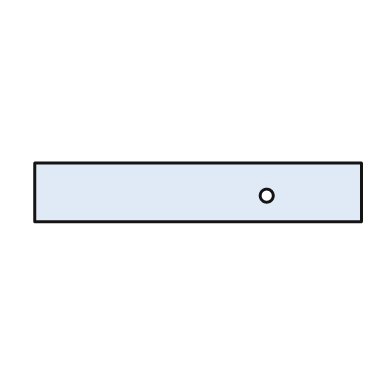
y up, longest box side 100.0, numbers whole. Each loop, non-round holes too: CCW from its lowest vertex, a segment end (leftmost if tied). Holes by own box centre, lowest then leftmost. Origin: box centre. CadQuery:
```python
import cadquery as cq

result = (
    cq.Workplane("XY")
    .moveTo(-50.0, -9.0)
    .lineTo(50.0, -9.0)
    .lineTo(50.0, 9.0)
    .lineTo(-50.0, 9.0)
    .close()
    .moveTo(21.0, -1.0)
    .circle(2.0)
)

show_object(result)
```